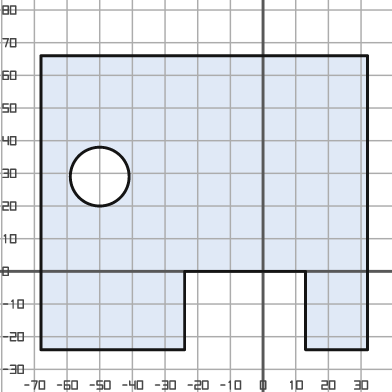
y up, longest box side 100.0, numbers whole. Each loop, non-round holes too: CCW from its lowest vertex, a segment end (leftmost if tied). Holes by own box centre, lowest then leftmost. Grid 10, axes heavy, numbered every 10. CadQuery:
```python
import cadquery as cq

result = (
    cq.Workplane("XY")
    .moveTo(-68.0, -24.0)
    .lineTo(-24.0, -24.0)
    .lineTo(-24.0, 0.0)
    .lineTo(13.0, 0.0)
    .lineTo(13.0, -24.0)
    .lineTo(32.0, -24.0)
    .lineTo(32.0, 66.0)
    .lineTo(-68.0, 66.0)
    .close()
    .moveTo(-50.0, 29.0)
    .circle(9.0)
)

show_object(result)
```